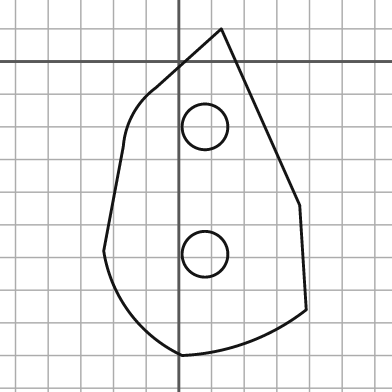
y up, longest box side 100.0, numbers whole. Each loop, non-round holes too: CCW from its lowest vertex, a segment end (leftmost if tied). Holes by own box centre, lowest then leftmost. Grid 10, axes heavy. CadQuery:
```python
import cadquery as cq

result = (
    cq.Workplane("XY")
    .moveTo(1.0, -90.0)
    .threePointArc((21.0, -86.0), (39.0, -76.0))
    .lineTo(37.0, -44.0)
    .lineTo(13.0, 10.0)
    .lineTo(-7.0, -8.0)
    .threePointArc((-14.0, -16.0), (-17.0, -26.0))
    .lineTo(-23.0, -58.0)
    .threePointArc((-15.0, -77.0), (1.0, -90.0))
    .close()
    .moveTo(8.0, -59.0)
    .circle(7.0)
    .moveTo(8.0, -20.0)
    .circle(7.0)
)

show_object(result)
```